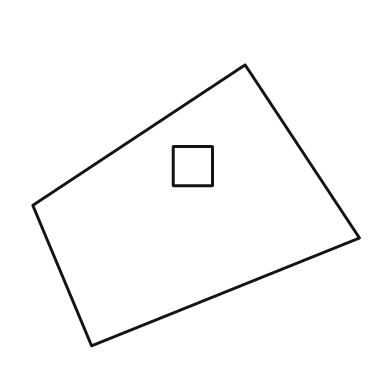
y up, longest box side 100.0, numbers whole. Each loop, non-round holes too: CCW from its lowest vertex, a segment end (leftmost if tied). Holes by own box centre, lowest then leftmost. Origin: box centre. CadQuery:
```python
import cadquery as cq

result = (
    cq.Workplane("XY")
    .moveTo(-32.0, -43.0)
    .lineTo(50.0, -10.0)
    .lineTo(15.0, 43.0)
    .lineTo(-50.0, 0.0)
    .close()
    .moveTo(-7.0, 6.0)
    .lineTo(5.0, 6.0)
    .lineTo(5.0, 18.0)
    .lineTo(-7.0, 18.0)
    .close()
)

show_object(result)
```